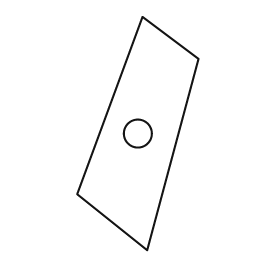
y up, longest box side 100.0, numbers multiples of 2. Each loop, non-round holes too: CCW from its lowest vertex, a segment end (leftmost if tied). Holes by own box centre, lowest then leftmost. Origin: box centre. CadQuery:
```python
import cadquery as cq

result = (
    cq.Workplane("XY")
    .moveTo(4.0, -50.0)
    .lineTo(26.0, 32.0)
    .lineTo(2.0, 50.0)
    .lineTo(-26.0, -26.0)
    .close()
    .moveTo(0.0, 0.0)
    .circle(6.0)
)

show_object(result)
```